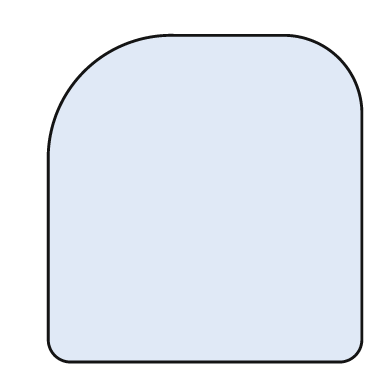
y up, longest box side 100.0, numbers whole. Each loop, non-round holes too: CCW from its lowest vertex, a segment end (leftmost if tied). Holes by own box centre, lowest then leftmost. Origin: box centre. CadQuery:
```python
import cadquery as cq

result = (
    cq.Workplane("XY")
    .moveTo(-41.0, -50.0)
    .lineTo(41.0, -50.0)
    .threePointArc((46.0, -48.0), (48.0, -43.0))
    .lineTo(48.0, 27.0)
    .threePointArc((41.0, 43.0), (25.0, 50.0))
    .lineTo(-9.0, 50.0)
    .threePointArc((-37.0, 39.0), (-48.0, 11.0))
    .lineTo(-48.0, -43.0)
    .threePointArc((-46.0, -48.0), (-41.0, -50.0))
    .close()
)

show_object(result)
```